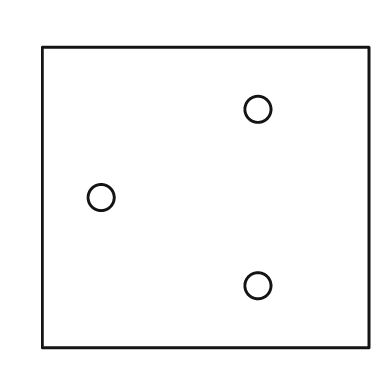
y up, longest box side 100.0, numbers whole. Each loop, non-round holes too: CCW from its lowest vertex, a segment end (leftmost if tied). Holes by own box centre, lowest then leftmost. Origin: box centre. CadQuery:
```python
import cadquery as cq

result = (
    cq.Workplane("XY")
    .moveTo(-50.0, -46.0)
    .lineTo(50.0, -46.0)
    .lineTo(50.0, 46.0)
    .lineTo(-50.0, 46.0)
    .close()
    .moveTo(16.0, -27.0)
    .circle(4.0)
    .moveTo(-32.0, 0.0)
    .circle(4.0)
    .moveTo(16.0, 27.0)
    .circle(4.0)
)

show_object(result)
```